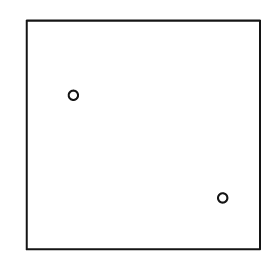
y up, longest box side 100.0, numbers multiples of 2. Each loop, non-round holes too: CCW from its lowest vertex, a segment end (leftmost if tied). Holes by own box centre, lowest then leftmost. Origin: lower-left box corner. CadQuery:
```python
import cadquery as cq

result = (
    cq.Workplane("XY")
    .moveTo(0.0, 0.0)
    .lineTo(100.0, 0.0)
    .lineTo(100.0, 98.0)
    .lineTo(0.0, 98.0)
    .close()
    .moveTo(84.0, 22.0)
    .circle(2.0)
    .moveTo(20.0, 66.0)
    .circle(2.0)
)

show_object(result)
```